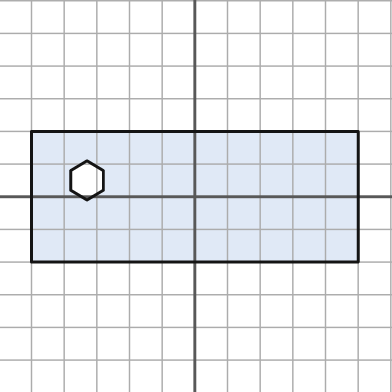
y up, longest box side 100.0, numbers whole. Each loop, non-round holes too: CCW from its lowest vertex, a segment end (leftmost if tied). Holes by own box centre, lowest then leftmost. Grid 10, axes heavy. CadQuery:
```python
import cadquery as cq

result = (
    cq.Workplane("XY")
    .moveTo(-50.0, -20.0)
    .lineTo(50.0, -20.0)
    .lineTo(50.0, 20.0)
    .lineTo(-50.0, 20.0)
    .close()
    .moveTo(-33.0, -1.0)
    .lineTo(-28.0, 2.0)
    .lineTo(-28.0, 8.0)
    .lineTo(-33.0, 11.0)
    .lineTo(-38.0, 8.0)
    .lineTo(-38.0, 2.0)
    .close()
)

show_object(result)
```